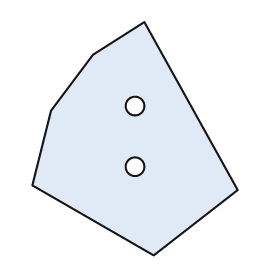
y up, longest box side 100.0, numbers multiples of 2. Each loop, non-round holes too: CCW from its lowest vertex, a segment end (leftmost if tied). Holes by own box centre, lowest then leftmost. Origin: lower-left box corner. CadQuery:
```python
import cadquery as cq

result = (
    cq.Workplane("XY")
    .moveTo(52.0, 0.0)
    .lineTo(88.0, 28.0)
    .lineTo(48.0, 100.0)
    .lineTo(26.0, 86.0)
    .lineTo(8.0, 62.0)
    .lineTo(0.0, 30.0)
    .close()
    .moveTo(44.0, 38.0)
    .circle(4.0)
    .moveTo(44.0, 64.0)
    .circle(4.0)
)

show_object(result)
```